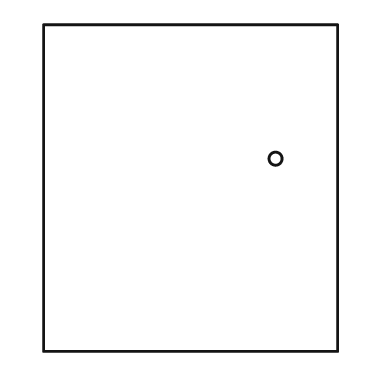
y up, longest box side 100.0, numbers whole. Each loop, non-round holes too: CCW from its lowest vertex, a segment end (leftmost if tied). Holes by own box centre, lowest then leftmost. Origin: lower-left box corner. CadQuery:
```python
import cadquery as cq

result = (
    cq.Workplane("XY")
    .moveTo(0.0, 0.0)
    .lineTo(90.0, 0.0)
    .lineTo(90.0, 100.0)
    .lineTo(0.0, 100.0)
    .close()
    .moveTo(71.0, 59.0)
    .circle(2.0)
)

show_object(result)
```